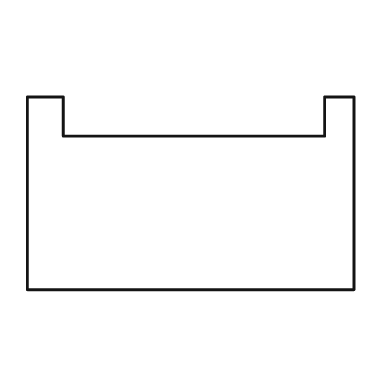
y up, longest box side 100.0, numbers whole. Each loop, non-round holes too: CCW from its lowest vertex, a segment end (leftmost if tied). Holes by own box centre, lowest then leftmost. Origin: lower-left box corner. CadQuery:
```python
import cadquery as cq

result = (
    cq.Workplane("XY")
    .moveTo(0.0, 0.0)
    .lineTo(100.0, 0.0)
    .lineTo(100.0, 59.0)
    .lineTo(91.0, 59.0)
    .lineTo(91.0, 47.0)
    .lineTo(11.0, 47.0)
    .lineTo(11.0, 59.0)
    .lineTo(0.0, 59.0)
    .close()
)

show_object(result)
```